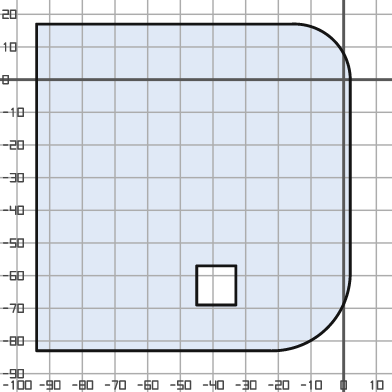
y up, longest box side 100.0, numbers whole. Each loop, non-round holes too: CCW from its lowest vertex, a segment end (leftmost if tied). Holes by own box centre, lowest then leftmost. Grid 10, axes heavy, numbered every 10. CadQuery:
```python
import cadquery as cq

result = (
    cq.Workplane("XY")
    .moveTo(-94.0, -83.0)
    .lineTo(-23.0, -83.0)
    .threePointArc((-5.0, -76.0), (2.0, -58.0))
    .lineTo(2.0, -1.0)
    .threePointArc((-3.0, 12.0), (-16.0, 17.0))
    .lineTo(-94.0, 17.0)
    .close()
    .moveTo(-45.0, -69.0)
    .lineTo(-33.0, -69.0)
    .lineTo(-33.0, -57.0)
    .lineTo(-45.0, -57.0)
    .close()
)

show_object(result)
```